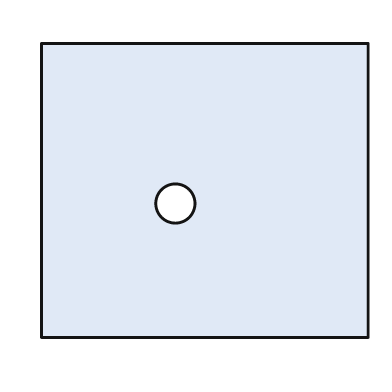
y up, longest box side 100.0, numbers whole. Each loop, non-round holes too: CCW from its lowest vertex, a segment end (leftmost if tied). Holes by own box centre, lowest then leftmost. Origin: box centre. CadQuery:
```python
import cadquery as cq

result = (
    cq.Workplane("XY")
    .moveTo(-50.0, -45.0)
    .lineTo(50.0, -45.0)
    .lineTo(50.0, 45.0)
    .lineTo(-50.0, 45.0)
    .close()
    .moveTo(-9.0, -4.0)
    .circle(6.0)
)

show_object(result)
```